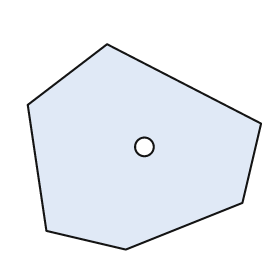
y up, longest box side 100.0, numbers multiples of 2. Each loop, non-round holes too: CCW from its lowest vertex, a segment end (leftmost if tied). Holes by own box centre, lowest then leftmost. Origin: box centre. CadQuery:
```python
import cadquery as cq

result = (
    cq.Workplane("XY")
    .moveTo(-8.0, -44.0)
    .lineTo(42.0, -24.0)
    .lineTo(50.0, 10.0)
    .lineTo(-16.0, 44.0)
    .lineTo(-50.0, 18.0)
    .lineTo(-42.0, -36.0)
    .close()
    .moveTo(0.0, 0.0)
    .circle(4.0)
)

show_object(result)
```